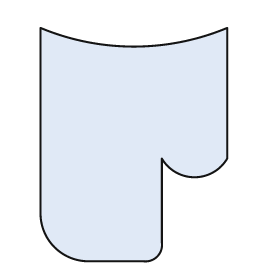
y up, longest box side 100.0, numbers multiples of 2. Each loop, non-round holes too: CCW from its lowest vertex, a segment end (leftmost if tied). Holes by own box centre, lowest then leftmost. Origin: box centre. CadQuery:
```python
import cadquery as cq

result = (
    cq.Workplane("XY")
    .moveTo(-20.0, -50.0)
    .lineTo(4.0, -50.0)
    .threePointArc((10.0, -48.0), (12.0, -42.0))
    .lineTo(12.0, -6.0)
    .threePointArc((26.0, -14.0), (40.0, -6.0))
    .lineTo(40.0, 50.0)
    .threePointArc((0.0, 42.0), (-40.0, 50.0))
    .lineTo(-40.0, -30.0)
    .threePointArc((-34.0, -44.0), (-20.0, -50.0))
    .close()
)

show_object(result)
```